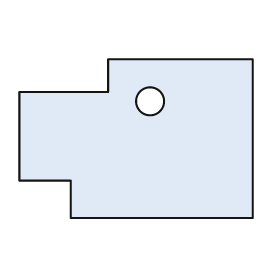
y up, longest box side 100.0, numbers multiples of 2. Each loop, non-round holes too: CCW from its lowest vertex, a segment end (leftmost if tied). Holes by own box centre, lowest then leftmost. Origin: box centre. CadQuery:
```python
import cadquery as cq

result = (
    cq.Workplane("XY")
    .moveTo(-28.0, -34.0)
    .lineTo(50.0, -34.0)
    .lineTo(50.0, 34.0)
    .lineTo(-12.0, 34.0)
    .lineTo(-12.0, 20.0)
    .lineTo(-50.0, 20.0)
    .lineTo(-50.0, -18.0)
    .lineTo(-28.0, -18.0)
    .close()
    .moveTo(6.0, 16.0)
    .circle(6.0)
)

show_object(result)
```